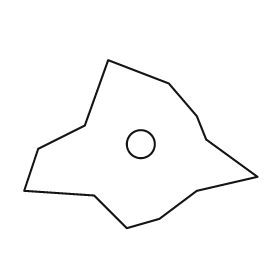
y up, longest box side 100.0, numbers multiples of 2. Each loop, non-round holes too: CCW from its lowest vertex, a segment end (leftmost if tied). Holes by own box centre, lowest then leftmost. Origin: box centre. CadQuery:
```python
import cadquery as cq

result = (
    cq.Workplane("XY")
    .moveTo(-6.0, -36.0)
    .lineTo(8.0, -32.0)
    .lineTo(24.0, -20.0)
    .lineTo(50.0, -14.0)
    .lineTo(28.0, 2.0)
    .lineTo(24.0, 12.0)
    .lineTo(12.0, 26.0)
    .lineTo(-14.0, 36.0)
    .lineTo(-24.0, 8.0)
    .lineTo(-44.0, -2.0)
    .lineTo(-50.0, -20.0)
    .lineTo(-20.0, -22.0)
    .close()
    .moveTo(0.0, 0.0)
    .circle(6.0)
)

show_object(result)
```